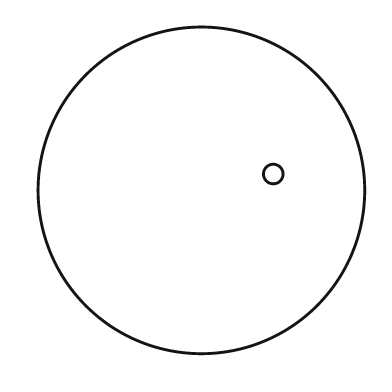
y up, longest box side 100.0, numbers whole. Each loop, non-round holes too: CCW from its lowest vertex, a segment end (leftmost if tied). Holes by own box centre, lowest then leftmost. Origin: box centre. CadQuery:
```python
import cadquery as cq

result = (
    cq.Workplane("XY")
    .moveTo(0.0, 0.0)
    .circle(50.0)
    .moveTo(22.0, 5.0)
    .circle(3.0)
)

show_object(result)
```